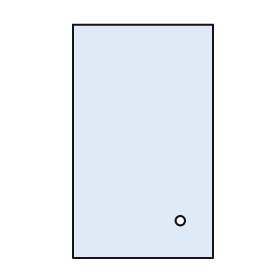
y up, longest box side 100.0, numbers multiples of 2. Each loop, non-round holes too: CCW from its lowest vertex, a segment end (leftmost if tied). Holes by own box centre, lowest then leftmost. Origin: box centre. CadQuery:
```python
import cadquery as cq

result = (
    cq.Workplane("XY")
    .moveTo(-30.0, -50.0)
    .lineTo(30.0, -50.0)
    .lineTo(30.0, 50.0)
    .lineTo(-30.0, 50.0)
    .close()
    .moveTo(16.0, -34.0)
    .circle(2.0)
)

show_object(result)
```